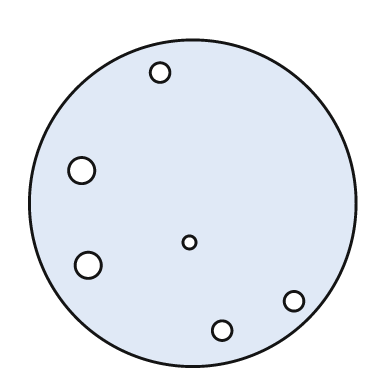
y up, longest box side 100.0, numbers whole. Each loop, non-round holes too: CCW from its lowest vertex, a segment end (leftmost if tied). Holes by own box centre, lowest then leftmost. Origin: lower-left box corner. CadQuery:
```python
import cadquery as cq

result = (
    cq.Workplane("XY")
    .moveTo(50.0, 50.0)
    .circle(50.0)
    .moveTo(59.0, 11.0)
    .circle(3.0)
    .moveTo(81.0, 20.0)
    .circle(3.0)
    .moveTo(18.0, 31.0)
    .circle(4.0)
    .moveTo(49.0, 38.0)
    .circle(2.0)
    .moveTo(16.0, 60.0)
    .circle(4.0)
    .moveTo(40.0, 90.0)
    .circle(3.0)
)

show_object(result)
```